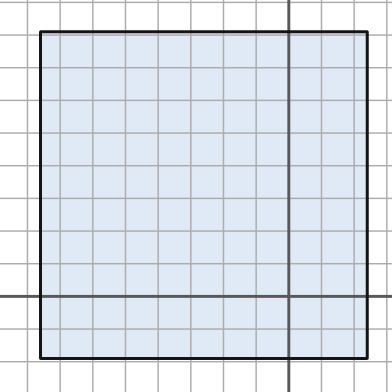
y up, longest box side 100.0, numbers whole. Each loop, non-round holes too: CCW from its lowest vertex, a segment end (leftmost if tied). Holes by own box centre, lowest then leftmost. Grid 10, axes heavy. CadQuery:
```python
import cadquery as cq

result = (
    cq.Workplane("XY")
    .moveTo(-76.0, -19.0)
    .lineTo(24.0, -19.0)
    .lineTo(24.0, 81.0)
    .lineTo(-76.0, 81.0)
    .close()
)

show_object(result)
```